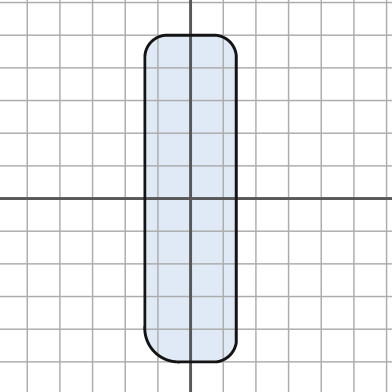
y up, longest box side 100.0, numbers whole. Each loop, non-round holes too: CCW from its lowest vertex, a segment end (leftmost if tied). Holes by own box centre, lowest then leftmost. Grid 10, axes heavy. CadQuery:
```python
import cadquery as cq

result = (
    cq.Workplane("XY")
    .moveTo(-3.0, -50.0)
    .lineTo(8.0, -50.0)
    .threePointArc((12.0, -48.0), (14.0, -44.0))
    .lineTo(14.0, 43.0)
    .threePointArc((12.0, 48.0), (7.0, 50.0))
    .lineTo(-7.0, 50.0)
    .threePointArc((-12.0, 48.0), (-14.0, 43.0))
    .lineTo(-14.0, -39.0)
    .threePointArc((-11.0, -47.0), (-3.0, -50.0))
    .close()
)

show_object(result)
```